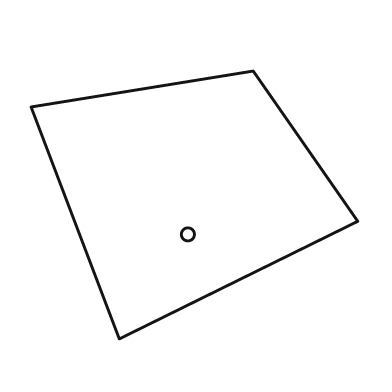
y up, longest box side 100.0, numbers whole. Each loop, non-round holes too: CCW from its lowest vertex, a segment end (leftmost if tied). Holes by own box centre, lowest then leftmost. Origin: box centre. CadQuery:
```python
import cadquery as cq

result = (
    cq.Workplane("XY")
    .moveTo(-23.0, -41.0)
    .lineTo(50.0, -5.0)
    .lineTo(18.0, 41.0)
    .lineTo(-50.0, 30.0)
    .close()
    .moveTo(-2.0, -9.0)
    .circle(2.0)
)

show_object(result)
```